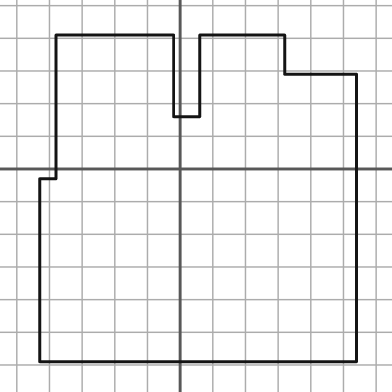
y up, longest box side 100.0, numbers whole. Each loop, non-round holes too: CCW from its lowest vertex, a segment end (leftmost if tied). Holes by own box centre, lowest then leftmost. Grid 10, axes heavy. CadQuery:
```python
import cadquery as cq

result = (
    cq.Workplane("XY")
    .moveTo(-43.0, -59.0)
    .lineTo(54.0, -59.0)
    .lineTo(54.0, 29.0)
    .lineTo(32.0, 29.0)
    .lineTo(32.0, 41.0)
    .lineTo(6.0, 41.0)
    .lineTo(6.0, 16.0)
    .lineTo(-2.0, 16.0)
    .lineTo(-2.0, 41.0)
    .lineTo(-38.0, 41.0)
    .lineTo(-38.0, -3.0)
    .lineTo(-43.0, -3.0)
    .close()
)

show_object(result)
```